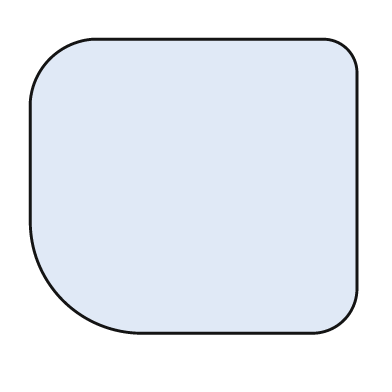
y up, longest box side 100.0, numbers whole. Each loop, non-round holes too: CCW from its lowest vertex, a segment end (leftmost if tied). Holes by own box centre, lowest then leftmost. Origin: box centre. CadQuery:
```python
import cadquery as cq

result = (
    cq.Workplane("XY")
    .moveTo(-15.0, -45.0)
    .lineTo(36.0, -45.0)
    .threePointArc((46.0, -41.0), (50.0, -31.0))
    .lineTo(50.0, 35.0)
    .threePointArc((47.0, 42.0), (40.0, 45.0))
    .lineTo(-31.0, 45.0)
    .threePointArc((-44.0, 39.0), (-50.0, 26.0))
    .lineTo(-50.0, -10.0)
    .threePointArc((-40.0, -35.0), (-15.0, -45.0))
    .close()
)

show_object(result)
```